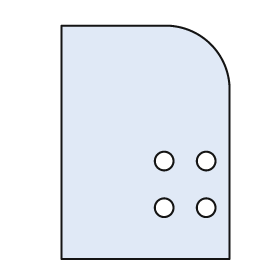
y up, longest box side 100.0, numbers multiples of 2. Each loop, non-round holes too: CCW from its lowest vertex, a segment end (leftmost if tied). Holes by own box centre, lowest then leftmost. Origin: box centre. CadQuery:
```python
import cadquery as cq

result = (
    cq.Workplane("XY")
    .moveTo(-36.0, -50.0)
    .lineTo(36.0, -50.0)
    .lineTo(36.0, 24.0)
    .threePointArc((28.0, 42.0), (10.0, 50.0))
    .lineTo(-36.0, 50.0)
    .close()
    .moveTo(8.0, -28.0)
    .circle(4.0)
    .moveTo(26.0, -28.0)
    .circle(4.0)
    .moveTo(8.0, -8.0)
    .circle(4.0)
    .moveTo(26.0, -8.0)
    .circle(4.0)
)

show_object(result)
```